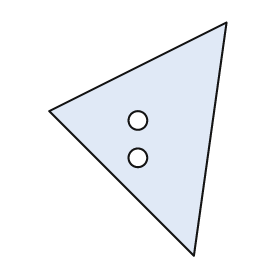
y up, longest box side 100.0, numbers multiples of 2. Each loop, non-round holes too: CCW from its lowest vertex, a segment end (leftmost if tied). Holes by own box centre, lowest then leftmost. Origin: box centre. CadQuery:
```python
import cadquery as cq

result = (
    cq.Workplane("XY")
    .moveTo(24.0, -50.0)
    .lineTo(38.0, 50.0)
    .lineTo(-38.0, 12.0)
    .close()
    .moveTo(0.0, -8.0)
    .circle(4.0)
    .moveTo(0.0, 8.0)
    .circle(4.0)
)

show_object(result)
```